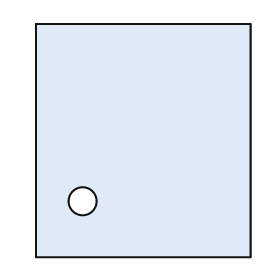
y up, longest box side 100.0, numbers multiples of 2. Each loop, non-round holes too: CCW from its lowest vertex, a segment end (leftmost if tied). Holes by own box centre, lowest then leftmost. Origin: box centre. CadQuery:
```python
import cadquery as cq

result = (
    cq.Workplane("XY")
    .moveTo(-46.0, -50.0)
    .lineTo(46.0, -50.0)
    .lineTo(46.0, 50.0)
    .lineTo(-46.0, 50.0)
    .close()
    .moveTo(-26.0, -26.0)
    .circle(6.0)
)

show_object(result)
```